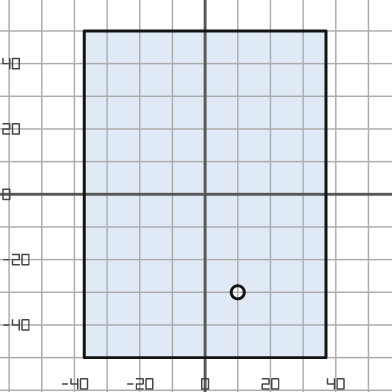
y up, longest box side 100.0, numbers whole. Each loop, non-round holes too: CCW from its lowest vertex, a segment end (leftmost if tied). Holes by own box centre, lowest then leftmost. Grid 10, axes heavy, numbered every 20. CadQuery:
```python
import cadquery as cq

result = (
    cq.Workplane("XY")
    .moveTo(-37.0, -50.0)
    .lineTo(37.0, -50.0)
    .lineTo(37.0, 50.0)
    .lineTo(-37.0, 50.0)
    .close()
    .moveTo(10.0, -30.0)
    .circle(2.0)
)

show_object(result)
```